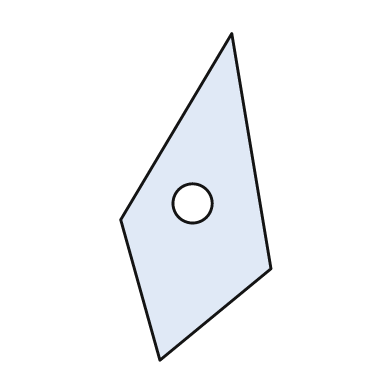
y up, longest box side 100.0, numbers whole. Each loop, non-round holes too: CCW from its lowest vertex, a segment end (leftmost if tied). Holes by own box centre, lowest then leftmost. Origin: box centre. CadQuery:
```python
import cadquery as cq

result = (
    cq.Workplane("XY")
    .moveTo(-11.0, -50.0)
    .lineTo(23.0, -22.0)
    .lineTo(11.0, 50.0)
    .lineTo(-23.0, -7.0)
    .close()
    .moveTo(-1.0, -2.0)
    .circle(6.0)
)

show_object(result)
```